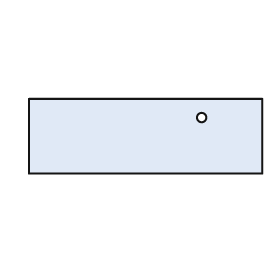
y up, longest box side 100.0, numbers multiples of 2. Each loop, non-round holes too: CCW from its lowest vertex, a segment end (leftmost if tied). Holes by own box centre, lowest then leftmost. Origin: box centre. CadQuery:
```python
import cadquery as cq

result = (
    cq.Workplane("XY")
    .moveTo(-50.0, -16.0)
    .lineTo(50.0, -16.0)
    .lineTo(50.0, 16.0)
    .lineTo(-50.0, 16.0)
    .close()
    .moveTo(24.0, 8.0)
    .circle(2.0)
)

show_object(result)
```